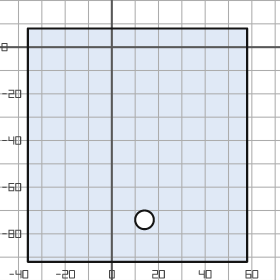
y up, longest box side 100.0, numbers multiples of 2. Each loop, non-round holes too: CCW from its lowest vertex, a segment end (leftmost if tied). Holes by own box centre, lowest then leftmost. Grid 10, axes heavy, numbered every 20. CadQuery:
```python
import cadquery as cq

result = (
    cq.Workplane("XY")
    .moveTo(-36.0, -92.0)
    .lineTo(58.0, -92.0)
    .lineTo(58.0, 8.0)
    .lineTo(-36.0, 8.0)
    .close()
    .moveTo(14.0, -74.0)
    .circle(4.0)
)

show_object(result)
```